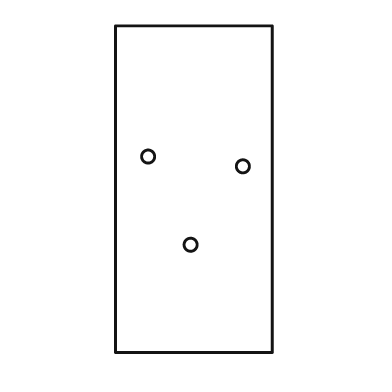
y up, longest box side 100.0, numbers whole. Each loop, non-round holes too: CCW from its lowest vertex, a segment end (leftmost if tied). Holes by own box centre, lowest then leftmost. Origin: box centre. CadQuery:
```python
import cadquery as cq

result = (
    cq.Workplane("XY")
    .moveTo(-24.0, -50.0)
    .lineTo(24.0, -50.0)
    .lineTo(24.0, 50.0)
    .lineTo(-24.0, 50.0)
    .close()
    .moveTo(-1.0, -17.0)
    .circle(2.0)
    .moveTo(15.0, 7.0)
    .circle(2.0)
    .moveTo(-14.0, 10.0)
    .circle(2.0)
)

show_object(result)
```